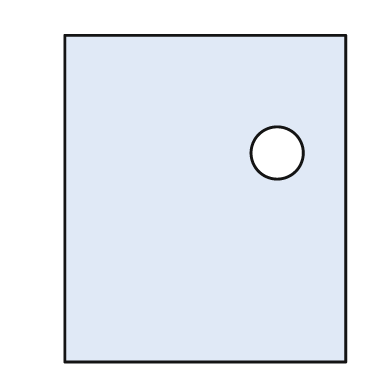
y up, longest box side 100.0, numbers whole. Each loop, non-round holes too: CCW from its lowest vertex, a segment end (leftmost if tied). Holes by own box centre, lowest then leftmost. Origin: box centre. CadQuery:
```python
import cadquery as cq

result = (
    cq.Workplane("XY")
    .moveTo(-43.0, -50.0)
    .lineTo(43.0, -50.0)
    .lineTo(43.0, 50.0)
    .lineTo(-43.0, 50.0)
    .close()
    .moveTo(22.0, 14.0)
    .circle(8.0)
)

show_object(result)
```